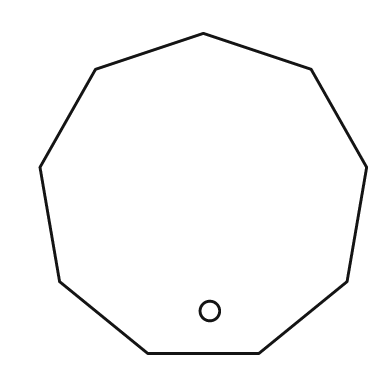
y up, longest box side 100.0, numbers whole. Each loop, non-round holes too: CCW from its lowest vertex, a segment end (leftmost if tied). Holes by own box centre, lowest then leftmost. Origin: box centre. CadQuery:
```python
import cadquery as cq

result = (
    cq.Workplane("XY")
    .moveTo(-17.0, -49.0)
    .lineTo(17.0, -49.0)
    .lineTo(44.0, -27.0)
    .lineTo(50.0, 8.0)
    .lineTo(33.0, 38.0)
    .lineTo(0.0, 49.0)
    .lineTo(-33.0, 38.0)
    .lineTo(-50.0, 8.0)
    .lineTo(-44.0, -27.0)
    .close()
    .moveTo(2.0, -36.0)
    .circle(3.0)
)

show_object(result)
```